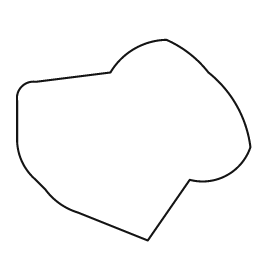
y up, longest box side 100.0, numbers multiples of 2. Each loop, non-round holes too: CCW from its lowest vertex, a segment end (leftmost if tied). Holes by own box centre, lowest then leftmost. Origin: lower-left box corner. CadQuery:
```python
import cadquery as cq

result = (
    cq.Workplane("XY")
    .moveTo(56.0, 0.0)
    .lineTo(74.0, 26.0)
    .threePointArc((90.0, 28.0), (100.0, 40.0))
    .threePointArc((94.0, 58.0), (82.0, 72.0))
    .threePointArc((74.0, 80.0), (64.0, 86.0))
    .threePointArc((50.0, 82.0), (40.0, 72.0))
    .lineTo(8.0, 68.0)
    .threePointArc((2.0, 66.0), (0.0, 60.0))
    .lineTo(0.0, 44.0)
    .threePointArc((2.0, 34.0), (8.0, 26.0))
    .lineTo(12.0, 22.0)
    .threePointArc((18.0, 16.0), (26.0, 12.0))
    .close()
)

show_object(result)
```